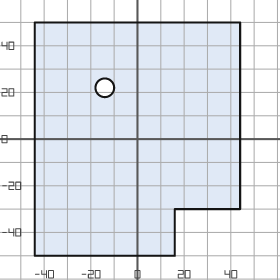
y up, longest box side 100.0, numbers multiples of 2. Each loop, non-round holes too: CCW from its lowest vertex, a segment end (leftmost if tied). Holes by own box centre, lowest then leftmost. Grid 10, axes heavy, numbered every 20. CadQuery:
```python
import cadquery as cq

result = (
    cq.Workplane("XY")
    .moveTo(-44.0, -50.0)
    .lineTo(16.0, -50.0)
    .lineTo(16.0, -30.0)
    .lineTo(44.0, -30.0)
    .lineTo(44.0, 50.0)
    .lineTo(-44.0, 50.0)
    .close()
    .moveTo(-14.0, 22.0)
    .circle(4.0)
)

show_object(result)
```